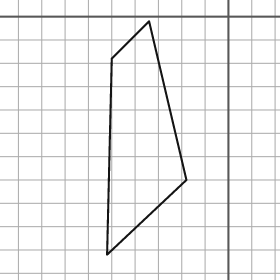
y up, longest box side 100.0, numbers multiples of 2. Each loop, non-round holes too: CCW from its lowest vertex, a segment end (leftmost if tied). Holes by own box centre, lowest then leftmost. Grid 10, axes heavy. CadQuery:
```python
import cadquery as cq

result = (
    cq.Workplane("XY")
    .moveTo(-52.0, -102.0)
    .lineTo(-18.0, -70.0)
    .lineTo(-34.0, -2.0)
    .lineTo(-50.0, -18.0)
    .close()
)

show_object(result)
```